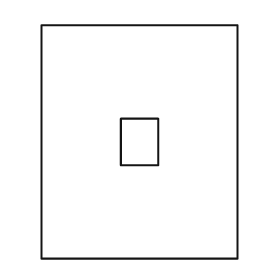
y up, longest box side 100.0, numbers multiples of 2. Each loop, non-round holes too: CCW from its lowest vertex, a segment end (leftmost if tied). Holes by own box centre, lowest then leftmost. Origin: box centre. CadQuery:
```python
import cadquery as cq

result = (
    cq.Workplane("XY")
    .moveTo(-42.0, -50.0)
    .lineTo(42.0, -50.0)
    .lineTo(42.0, 50.0)
    .lineTo(-42.0, 50.0)
    .close()
    .moveTo(-8.0, -10.0)
    .lineTo(8.0, -10.0)
    .lineTo(8.0, 10.0)
    .lineTo(-8.0, 10.0)
    .close()
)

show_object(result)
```